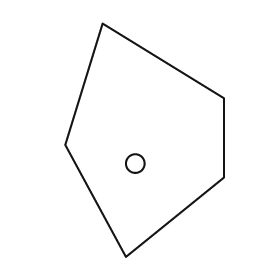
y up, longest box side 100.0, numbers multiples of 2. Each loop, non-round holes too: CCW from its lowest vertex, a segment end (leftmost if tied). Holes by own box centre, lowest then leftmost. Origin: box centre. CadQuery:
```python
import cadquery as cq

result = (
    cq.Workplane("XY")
    .moveTo(-8.0, -50.0)
    .lineTo(34.0, -16.0)
    .lineTo(34.0, 18.0)
    .lineTo(-18.0, 50.0)
    .lineTo(-34.0, -2.0)
    .close()
    .moveTo(-4.0, -10.0)
    .circle(4.0)
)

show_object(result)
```